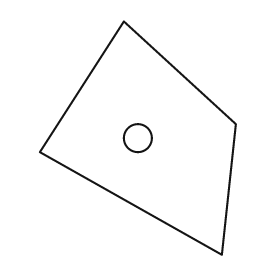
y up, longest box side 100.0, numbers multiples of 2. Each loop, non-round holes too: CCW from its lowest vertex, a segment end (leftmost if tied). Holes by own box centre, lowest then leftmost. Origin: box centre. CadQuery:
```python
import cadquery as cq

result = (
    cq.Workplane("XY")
    .moveTo(36.0, -50.0)
    .lineTo(42.0, 6.0)
    .lineTo(-6.0, 50.0)
    .lineTo(-42.0, -6.0)
    .close()
    .moveTo(0.0, 0.0)
    .circle(6.0)
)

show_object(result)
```